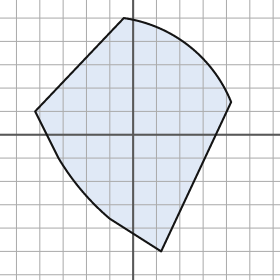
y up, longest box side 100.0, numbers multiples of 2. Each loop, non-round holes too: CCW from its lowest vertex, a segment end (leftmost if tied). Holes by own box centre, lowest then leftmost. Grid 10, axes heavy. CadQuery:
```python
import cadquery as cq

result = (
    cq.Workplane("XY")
    .moveTo(12.0, -50.0)
    .lineTo(42.0, 14.0)
    .threePointArc((24.0, 38.0), (-4.0, 50.0))
    .lineTo(-42.0, 10.0)
    .lineTo(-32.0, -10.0)
    .threePointArc((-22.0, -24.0), (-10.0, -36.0))
    .close()
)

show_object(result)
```